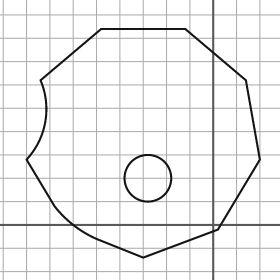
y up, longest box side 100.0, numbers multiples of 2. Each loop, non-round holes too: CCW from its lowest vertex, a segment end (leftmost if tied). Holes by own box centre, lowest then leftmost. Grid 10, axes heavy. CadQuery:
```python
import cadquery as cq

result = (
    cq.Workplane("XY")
    .moveTo(-30.0, -14.0)
    .lineTo(2.0, -2.0)
    .lineTo(20.0, 28.0)
    .lineTo(14.0, 62.0)
    .lineTo(-12.0, 84.0)
    .lineTo(-48.0, 84.0)
    .lineTo(-74.0, 62.0)
    .threePointArc((-72.0, 44.0), (-80.0, 28.0))
    .lineTo(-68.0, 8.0)
    .threePointArc((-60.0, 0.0), (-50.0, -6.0))
    .close()
    .moveTo(-28.0, 20.0)
    .circle(10.0)
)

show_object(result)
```